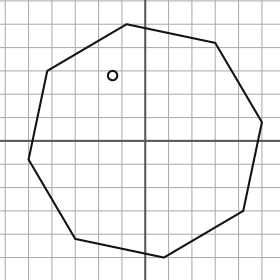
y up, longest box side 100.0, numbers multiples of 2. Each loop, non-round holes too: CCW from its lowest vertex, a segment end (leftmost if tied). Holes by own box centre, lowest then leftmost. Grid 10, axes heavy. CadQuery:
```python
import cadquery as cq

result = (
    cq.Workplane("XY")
    .moveTo(8.0, -50.0)
    .lineTo(42.0, -30.0)
    .lineTo(50.0, 8.0)
    .lineTo(30.0, 42.0)
    .lineTo(-8.0, 50.0)
    .lineTo(-42.0, 30.0)
    .lineTo(-50.0, -8.0)
    .lineTo(-30.0, -42.0)
    .close()
    .moveTo(-14.0, 28.0)
    .circle(2.0)
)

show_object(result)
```